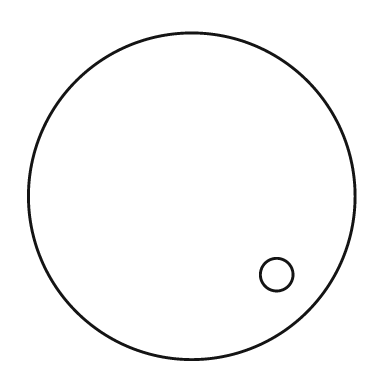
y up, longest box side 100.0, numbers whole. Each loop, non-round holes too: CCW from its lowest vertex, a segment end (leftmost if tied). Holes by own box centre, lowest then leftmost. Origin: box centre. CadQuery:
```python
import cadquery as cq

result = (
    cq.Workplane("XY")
    .moveTo(0.0, 0.0)
    .circle(50.0)
    .moveTo(26.0, -24.0)
    .circle(5.0)
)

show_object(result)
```